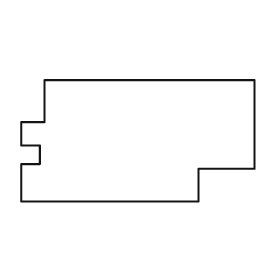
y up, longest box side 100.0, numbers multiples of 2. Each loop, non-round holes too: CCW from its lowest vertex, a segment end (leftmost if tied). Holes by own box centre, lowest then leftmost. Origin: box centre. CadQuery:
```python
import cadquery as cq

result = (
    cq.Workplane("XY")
    .moveTo(-50.0, -26.0)
    .lineTo(26.0, -26.0)
    .lineTo(26.0, -12.0)
    .lineTo(50.0, -12.0)
    .lineTo(50.0, 26.0)
    .lineTo(-40.0, 26.0)
    .lineTo(-40.0, 8.0)
    .lineTo(-50.0, 8.0)
    .lineTo(-50.0, -2.0)
    .lineTo(-42.0, -2.0)
    .lineTo(-42.0, -10.0)
    .lineTo(-50.0, -10.0)
    .close()
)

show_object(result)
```